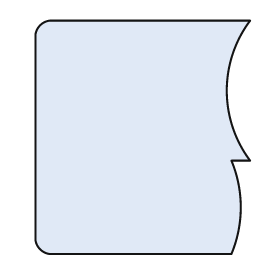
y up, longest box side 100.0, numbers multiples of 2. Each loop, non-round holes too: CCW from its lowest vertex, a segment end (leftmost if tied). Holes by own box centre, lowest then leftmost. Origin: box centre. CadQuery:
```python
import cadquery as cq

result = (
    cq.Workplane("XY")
    .moveTo(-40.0, -50.0)
    .lineTo(38.0, -50.0)
    .threePointArc((42.0, -30.0), (38.0, -10.0))
    .lineTo(46.0, -10.0)
    .threePointArc((36.0, 20.0), (46.0, 50.0))
    .lineTo(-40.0, 50.0)
    .threePointArc((-44.0, 48.0), (-46.0, 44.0))
    .lineTo(-46.0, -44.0)
    .threePointArc((-44.0, -48.0), (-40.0, -50.0))
    .close()
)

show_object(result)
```